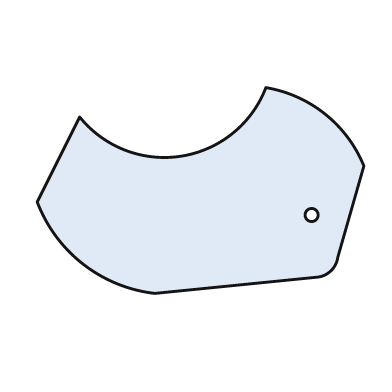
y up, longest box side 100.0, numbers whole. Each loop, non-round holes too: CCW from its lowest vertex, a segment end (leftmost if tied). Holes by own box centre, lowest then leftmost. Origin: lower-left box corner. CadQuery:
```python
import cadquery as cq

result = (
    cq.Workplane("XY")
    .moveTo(36.0, 0.0)
    .lineTo(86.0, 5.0)
    .threePointArc((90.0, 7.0), (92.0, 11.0))
    .lineTo(100.0, 39.0)
    .threePointArc((88.0, 55.0), (70.0, 63.0))
    .threePointArc((44.0, 42.0), (13.0, 54.0))
    .lineTo(0.0, 28.0)
    .threePointArc((14.0, 9.0), (36.0, 0.0))
    .close()
    .moveTo(84.0, 24.0)
    .circle(2.0)
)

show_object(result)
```